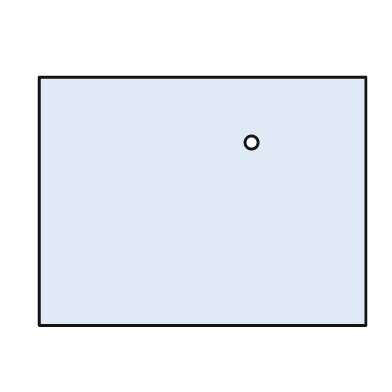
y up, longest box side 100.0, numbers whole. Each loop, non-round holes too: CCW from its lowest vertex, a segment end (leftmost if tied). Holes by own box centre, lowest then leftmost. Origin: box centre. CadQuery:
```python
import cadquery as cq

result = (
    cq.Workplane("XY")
    .moveTo(-50.0, -38.0)
    .lineTo(50.0, -38.0)
    .lineTo(50.0, 38.0)
    .lineTo(-50.0, 38.0)
    .close()
    .moveTo(15.0, 18.0)
    .circle(2.0)
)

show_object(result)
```